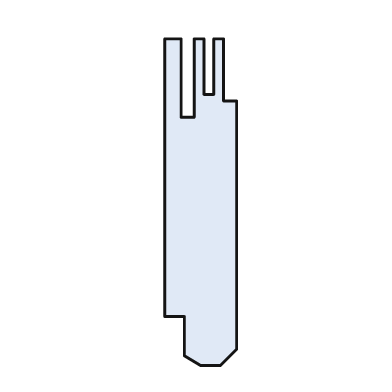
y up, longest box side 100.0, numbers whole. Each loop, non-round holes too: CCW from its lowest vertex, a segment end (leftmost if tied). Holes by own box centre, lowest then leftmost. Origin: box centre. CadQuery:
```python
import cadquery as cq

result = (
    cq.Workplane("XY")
    .moveTo(0.0, -50.0)
    .lineTo(6.0, -50.0)
    .lineTo(11.0, -45.0)
    .lineTo(11.0, 31.0)
    .lineTo(7.0, 31.0)
    .lineTo(7.0, 50.0)
    .lineTo(4.0, 50.0)
    .lineTo(4.0, 33.0)
    .lineTo(1.0, 33.0)
    .lineTo(1.0, 50.0)
    .lineTo(-2.0, 50.0)
    .lineTo(-2.0, 26.0)
    .lineTo(-6.0, 26.0)
    .lineTo(-6.0, 50.0)
    .lineTo(-11.0, 50.0)
    .lineTo(-11.0, -35.0)
    .lineTo(-5.0, -35.0)
    .lineTo(-5.0, -47.0)
    .close()
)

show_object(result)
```